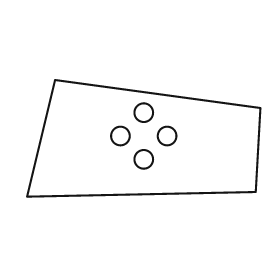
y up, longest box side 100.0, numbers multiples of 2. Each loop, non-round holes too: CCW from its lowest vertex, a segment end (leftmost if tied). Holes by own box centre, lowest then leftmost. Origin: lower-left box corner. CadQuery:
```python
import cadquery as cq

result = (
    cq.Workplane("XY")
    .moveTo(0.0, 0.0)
    .lineTo(98.0, 2.0)
    .lineTo(100.0, 38.0)
    .lineTo(12.0, 50.0)
    .close()
    .moveTo(50.0, 16.0)
    .circle(4.0)
    .moveTo(40.0, 26.0)
    .circle(4.0)
    .moveTo(60.0, 26.0)
    .circle(4.0)
    .moveTo(50.0, 36.0)
    .circle(4.0)
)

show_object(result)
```